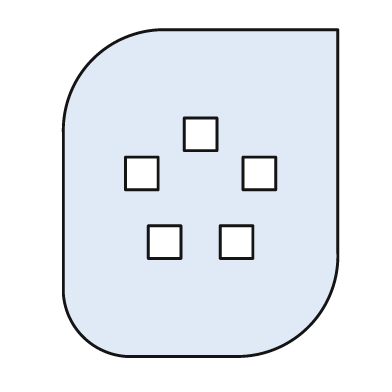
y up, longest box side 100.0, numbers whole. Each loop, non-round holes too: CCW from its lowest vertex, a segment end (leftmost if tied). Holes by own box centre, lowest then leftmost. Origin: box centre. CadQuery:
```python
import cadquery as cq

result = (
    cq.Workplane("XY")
    .moveTo(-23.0, -50.0)
    .lineTo(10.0, -50.0)
    .threePointArc((33.0, -41.0), (42.0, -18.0))
    .lineTo(42.0, 50.0)
    .lineTo(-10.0, 50.0)
    .threePointArc((-33.0, 41.0), (-42.0, 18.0))
    .lineTo(-42.0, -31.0)
    .threePointArc((-36.0, -44.0), (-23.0, -50.0))
    .close()
    .moveTo(-16.0, -20.0)
    .lineTo(-6.0, -20.0)
    .lineTo(-6.0, -10.0)
    .lineTo(-16.0, -10.0)
    .close()
    .moveTo(6.0, -20.0)
    .lineTo(16.0, -20.0)
    .lineTo(16.0, -10.0)
    .lineTo(6.0, -10.0)
    .close()
    .moveTo(-23.0, 1.0)
    .lineTo(-13.0, 1.0)
    .lineTo(-13.0, 11.0)
    .lineTo(-23.0, 11.0)
    .close()
    .moveTo(13.0, 1.0)
    .lineTo(23.0, 1.0)
    .lineTo(23.0, 11.0)
    .lineTo(13.0, 11.0)
    .close()
    .moveTo(-5.0, 13.0)
    .lineTo(5.0, 13.0)
    .lineTo(5.0, 23.0)
    .lineTo(-5.0, 23.0)
    .close()
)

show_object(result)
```